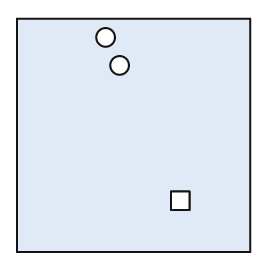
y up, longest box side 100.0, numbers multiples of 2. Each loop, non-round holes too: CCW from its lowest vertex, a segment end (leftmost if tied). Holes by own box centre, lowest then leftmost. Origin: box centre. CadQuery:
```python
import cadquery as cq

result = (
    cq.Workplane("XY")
    .moveTo(-50.0, -50.0)
    .lineTo(50.0, -50.0)
    .lineTo(50.0, 50.0)
    .lineTo(-50.0, 50.0)
    .close()
    .moveTo(16.0, -32.0)
    .lineTo(24.0, -32.0)
    .lineTo(24.0, -24.0)
    .lineTo(16.0, -24.0)
    .close()
    .moveTo(-6.0, 30.0)
    .circle(4.0)
    .moveTo(-12.0, 42.0)
    .circle(4.0)
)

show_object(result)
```